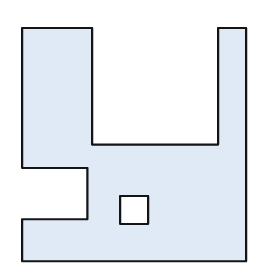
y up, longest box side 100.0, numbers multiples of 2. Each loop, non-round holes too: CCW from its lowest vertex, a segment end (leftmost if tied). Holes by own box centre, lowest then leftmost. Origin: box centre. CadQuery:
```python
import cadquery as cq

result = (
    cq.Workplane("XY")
    .moveTo(-48.0, -50.0)
    .lineTo(48.0, -50.0)
    .lineTo(48.0, 50.0)
    .lineTo(36.0, 50.0)
    .lineTo(36.0, 0.0)
    .lineTo(-18.0, 0.0)
    .lineTo(-18.0, 50.0)
    .lineTo(-48.0, 50.0)
    .lineTo(-48.0, -10.0)
    .lineTo(-20.0, -10.0)
    .lineTo(-20.0, -32.0)
    .lineTo(-48.0, -32.0)
    .close()
    .moveTo(-6.0, -34.0)
    .lineTo(6.0, -34.0)
    .lineTo(6.0, -22.0)
    .lineTo(-6.0, -22.0)
    .close()
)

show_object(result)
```